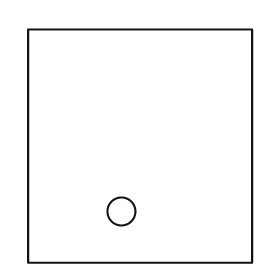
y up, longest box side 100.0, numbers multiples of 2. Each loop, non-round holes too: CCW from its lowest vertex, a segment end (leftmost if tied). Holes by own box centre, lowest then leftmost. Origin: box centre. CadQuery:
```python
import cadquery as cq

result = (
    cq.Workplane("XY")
    .moveTo(-48.0, -50.0)
    .lineTo(48.0, -50.0)
    .lineTo(48.0, 50.0)
    .lineTo(-48.0, 50.0)
    .close()
    .moveTo(-8.0, -28.0)
    .circle(6.0)
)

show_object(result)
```